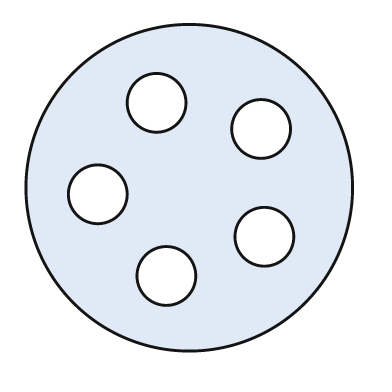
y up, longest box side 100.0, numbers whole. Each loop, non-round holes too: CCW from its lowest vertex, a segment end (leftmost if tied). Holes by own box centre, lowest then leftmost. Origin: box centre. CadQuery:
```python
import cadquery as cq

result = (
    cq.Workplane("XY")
    .moveTo(0.0, 0.0)
    .circle(50.0)
    .moveTo(-7.0, -27.0)
    .circle(9.0)
    .moveTo(23.0, -15.0)
    .circle(9.0)
    .moveTo(-28.0, -2.0)
    .circle(9.0)
    .moveTo(22.0, 18.0)
    .circle(9.0)
    .moveTo(-10.0, 26.0)
    .circle(9.0)
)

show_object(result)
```